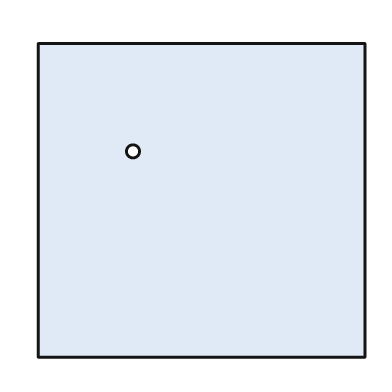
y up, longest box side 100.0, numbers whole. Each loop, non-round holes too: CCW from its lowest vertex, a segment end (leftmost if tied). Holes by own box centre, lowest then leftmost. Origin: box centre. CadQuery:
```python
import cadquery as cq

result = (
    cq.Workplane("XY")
    .moveTo(-50.0, -48.0)
    .lineTo(50.0, -48.0)
    .lineTo(50.0, 48.0)
    .lineTo(-50.0, 48.0)
    .close()
    .moveTo(-21.0, 15.0)
    .circle(2.0)
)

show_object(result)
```